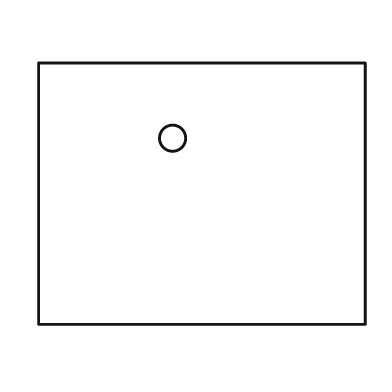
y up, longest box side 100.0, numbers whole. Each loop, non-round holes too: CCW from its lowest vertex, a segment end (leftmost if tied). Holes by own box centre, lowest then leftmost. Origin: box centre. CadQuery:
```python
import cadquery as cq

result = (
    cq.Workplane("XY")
    .moveTo(-50.0, -40.0)
    .lineTo(50.0, -40.0)
    .lineTo(50.0, 40.0)
    .lineTo(-50.0, 40.0)
    .close()
    .moveTo(-9.0, 17.0)
    .circle(4.0)
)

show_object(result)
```